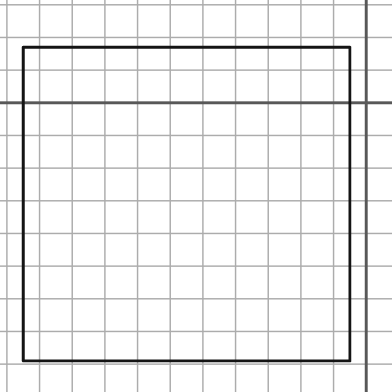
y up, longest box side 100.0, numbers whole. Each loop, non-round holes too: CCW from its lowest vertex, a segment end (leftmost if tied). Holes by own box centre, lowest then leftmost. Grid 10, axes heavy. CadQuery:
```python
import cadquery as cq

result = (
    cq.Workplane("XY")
    .moveTo(-105.0, -79.0)
    .lineTo(-5.0, -79.0)
    .lineTo(-5.0, 17.0)
    .lineTo(-105.0, 17.0)
    .close()
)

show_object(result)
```